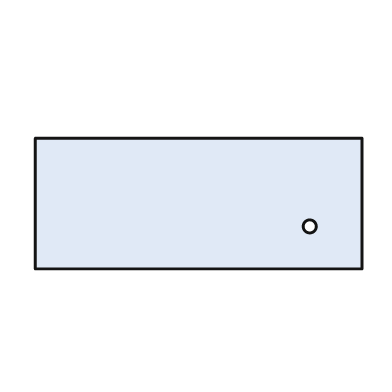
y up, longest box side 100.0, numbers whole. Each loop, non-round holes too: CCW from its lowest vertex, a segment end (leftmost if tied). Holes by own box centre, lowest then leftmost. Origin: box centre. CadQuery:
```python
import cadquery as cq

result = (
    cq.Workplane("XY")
    .moveTo(-50.0, -20.0)
    .lineTo(50.0, -20.0)
    .lineTo(50.0, 20.0)
    .lineTo(-50.0, 20.0)
    .close()
    .moveTo(34.0, -7.0)
    .circle(2.0)
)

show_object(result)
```